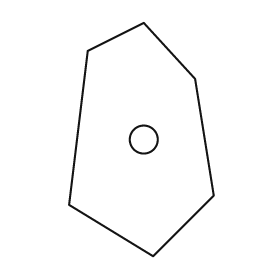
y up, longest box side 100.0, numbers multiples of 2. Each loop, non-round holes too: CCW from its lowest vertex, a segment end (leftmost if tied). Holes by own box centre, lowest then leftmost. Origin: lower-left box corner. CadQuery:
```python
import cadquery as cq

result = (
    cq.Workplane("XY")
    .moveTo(36.0, 0.0)
    .lineTo(62.0, 26.0)
    .lineTo(54.0, 76.0)
    .lineTo(32.0, 100.0)
    .lineTo(8.0, 88.0)
    .lineTo(0.0, 22.0)
    .close()
    .moveTo(32.0, 50.0)
    .circle(6.0)
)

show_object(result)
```